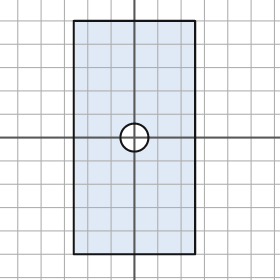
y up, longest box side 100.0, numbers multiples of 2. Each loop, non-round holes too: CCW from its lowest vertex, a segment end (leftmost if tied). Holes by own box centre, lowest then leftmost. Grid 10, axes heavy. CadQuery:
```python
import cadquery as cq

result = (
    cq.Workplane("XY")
    .moveTo(-26.0, -50.0)
    .lineTo(26.0, -50.0)
    .lineTo(26.0, 50.0)
    .lineTo(-26.0, 50.0)
    .close()
    .moveTo(0.0, 0.0)
    .circle(6.0)
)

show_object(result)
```